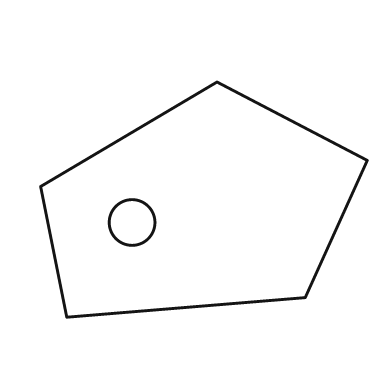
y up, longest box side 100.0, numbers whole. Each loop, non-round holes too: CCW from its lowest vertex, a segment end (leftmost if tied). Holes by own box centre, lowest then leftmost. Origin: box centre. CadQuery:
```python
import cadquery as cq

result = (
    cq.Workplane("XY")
    .moveTo(-42.0, -36.0)
    .lineTo(31.0, -30.0)
    .lineTo(50.0, 12.0)
    .lineTo(4.0, 36.0)
    .lineTo(-50.0, 4.0)
    .close()
    .moveTo(-22.0, -7.0)
    .circle(7.0)
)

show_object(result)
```